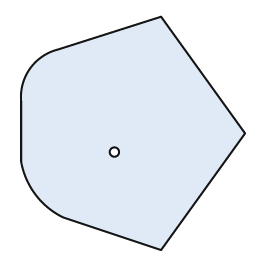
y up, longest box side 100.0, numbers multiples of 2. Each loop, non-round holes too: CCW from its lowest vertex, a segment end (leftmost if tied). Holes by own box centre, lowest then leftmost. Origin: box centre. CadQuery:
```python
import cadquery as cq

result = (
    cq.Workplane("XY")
    .moveTo(12.0, -50.0)
    .lineTo(48.0, 0.0)
    .lineTo(12.0, 50.0)
    .lineTo(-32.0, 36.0)
    .threePointArc((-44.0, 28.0), (-48.0, 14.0))
    .lineTo(-48.0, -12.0)
    .threePointArc((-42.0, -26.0), (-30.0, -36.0))
    .close()
    .moveTo(-8.0, -8.0)
    .circle(2.0)
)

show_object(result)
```